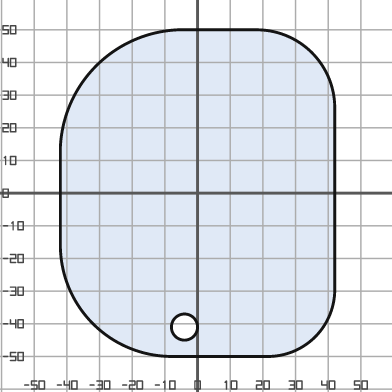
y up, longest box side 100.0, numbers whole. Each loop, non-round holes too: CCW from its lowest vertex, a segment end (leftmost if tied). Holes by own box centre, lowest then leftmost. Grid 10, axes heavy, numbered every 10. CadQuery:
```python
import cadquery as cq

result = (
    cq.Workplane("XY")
    .moveTo(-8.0, -50.0)
    .lineTo(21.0, -50.0)
    .threePointArc((36.0, -44.0), (42.0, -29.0))
    .lineTo(42.0, 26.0)
    .threePointArc((35.0, 43.0), (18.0, 50.0))
    .lineTo(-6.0, 50.0)
    .threePointArc((-31.0, 39.0), (-42.0, 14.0))
    .lineTo(-42.0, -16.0)
    .threePointArc((-32.0, -40.0), (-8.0, -50.0))
    .close()
    .moveTo(-4.0, -41.0)
    .circle(4.0)
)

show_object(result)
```